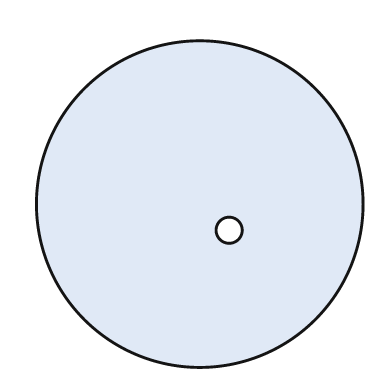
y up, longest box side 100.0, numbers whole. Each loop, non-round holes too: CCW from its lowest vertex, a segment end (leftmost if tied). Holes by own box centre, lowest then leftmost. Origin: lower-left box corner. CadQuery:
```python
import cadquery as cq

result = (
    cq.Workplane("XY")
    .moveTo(50.0, 50.0)
    .circle(50.0)
    .moveTo(59.0, 42.0)
    .circle(4.0)
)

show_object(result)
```